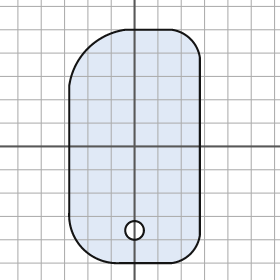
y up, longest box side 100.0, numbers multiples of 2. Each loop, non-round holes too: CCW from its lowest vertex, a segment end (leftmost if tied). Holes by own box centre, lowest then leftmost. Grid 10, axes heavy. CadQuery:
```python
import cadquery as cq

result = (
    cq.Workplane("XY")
    .moveTo(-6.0, -50.0)
    .lineTo(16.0, -50.0)
    .threePointArc((24.0, -46.0), (28.0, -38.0))
    .lineTo(28.0, 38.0)
    .threePointArc((24.0, 46.0), (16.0, 50.0))
    .lineTo(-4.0, 50.0)
    .threePointArc((-20.0, 42.0), (-28.0, 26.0))
    .lineTo(-28.0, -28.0)
    .threePointArc((-22.0, -44.0), (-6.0, -50.0))
    .close()
    .moveTo(0.0, -36.0)
    .circle(4.0)
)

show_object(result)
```